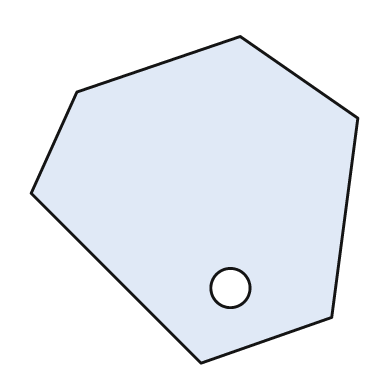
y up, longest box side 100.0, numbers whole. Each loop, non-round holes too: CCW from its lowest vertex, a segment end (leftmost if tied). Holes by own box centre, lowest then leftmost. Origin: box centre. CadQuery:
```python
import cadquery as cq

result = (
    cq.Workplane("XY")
    .moveTo(2.0, -50.0)
    .lineTo(42.0, -36.0)
    .lineTo(50.0, 25.0)
    .lineTo(14.0, 50.0)
    .lineTo(-36.0, 33.0)
    .lineTo(-50.0, 2.0)
    .close()
    .moveTo(11.0, -27.0)
    .circle(6.0)
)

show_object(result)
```